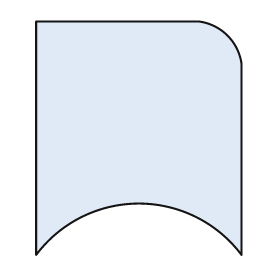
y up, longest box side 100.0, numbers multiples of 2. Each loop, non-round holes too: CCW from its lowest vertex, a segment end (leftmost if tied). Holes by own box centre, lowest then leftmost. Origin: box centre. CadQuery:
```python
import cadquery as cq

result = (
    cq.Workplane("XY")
    .moveTo(-44.0, -50.0)
    .threePointArc((0.0, -28.0), (44.0, -50.0))
    .lineTo(44.0, 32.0)
    .threePointArc((38.0, 44.0), (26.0, 50.0))
    .lineTo(-44.0, 50.0)
    .close()
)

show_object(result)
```